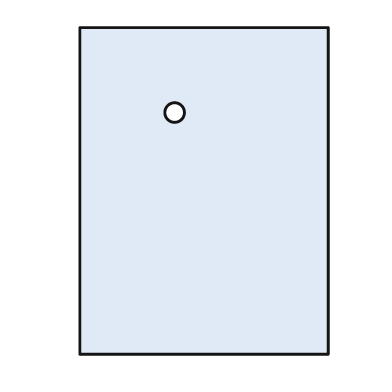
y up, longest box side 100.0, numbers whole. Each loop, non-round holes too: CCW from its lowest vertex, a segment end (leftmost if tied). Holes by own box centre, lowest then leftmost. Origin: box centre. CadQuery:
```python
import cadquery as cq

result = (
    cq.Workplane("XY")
    .moveTo(-38.0, -50.0)
    .lineTo(38.0, -50.0)
    .lineTo(38.0, 50.0)
    .lineTo(-38.0, 50.0)
    .close()
    .moveTo(-9.0, 24.0)
    .circle(3.0)
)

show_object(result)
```